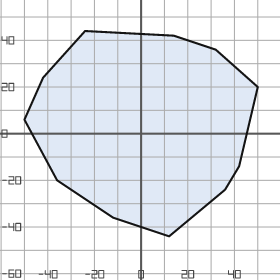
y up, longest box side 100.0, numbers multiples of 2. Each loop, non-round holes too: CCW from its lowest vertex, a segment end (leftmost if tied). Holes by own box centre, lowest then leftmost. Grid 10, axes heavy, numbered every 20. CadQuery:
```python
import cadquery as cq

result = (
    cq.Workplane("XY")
    .moveTo(12.0, -44.0)
    .lineTo(36.0, -24.0)
    .lineTo(42.0, -14.0)
    .lineTo(50.0, 20.0)
    .lineTo(32.0, 36.0)
    .lineTo(14.0, 42.0)
    .lineTo(-24.0, 44.0)
    .lineTo(-42.0, 24.0)
    .lineTo(-50.0, 6.0)
    .lineTo(-36.0, -20.0)
    .lineTo(-12.0, -36.0)
    .close()
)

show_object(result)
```